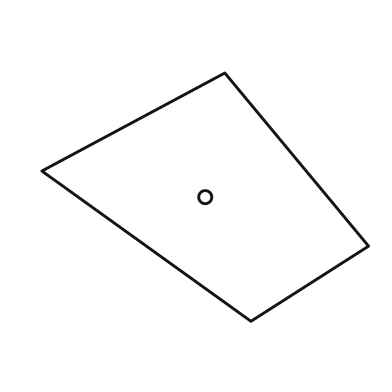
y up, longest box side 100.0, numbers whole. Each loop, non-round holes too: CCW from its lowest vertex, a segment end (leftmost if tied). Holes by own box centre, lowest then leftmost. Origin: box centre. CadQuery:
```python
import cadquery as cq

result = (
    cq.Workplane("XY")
    .moveTo(14.0, -38.0)
    .lineTo(50.0, -15.0)
    .lineTo(6.0, 38.0)
    .lineTo(-50.0, 8.0)
    .close()
    .moveTo(0.0, 0.0)
    .circle(2.0)
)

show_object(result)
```